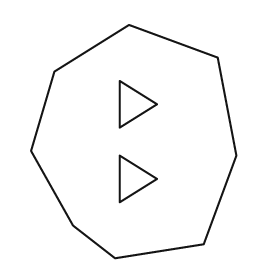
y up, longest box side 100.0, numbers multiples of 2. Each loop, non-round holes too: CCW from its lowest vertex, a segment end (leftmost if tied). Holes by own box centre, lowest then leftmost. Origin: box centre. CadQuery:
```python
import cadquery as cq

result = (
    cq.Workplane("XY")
    .moveTo(-8.0, -50.0)
    .lineTo(30.0, -44.0)
    .lineTo(44.0, -6.0)
    .lineTo(36.0, 36.0)
    .lineTo(-2.0, 50.0)
    .lineTo(-34.0, 30.0)
    .lineTo(-44.0, -4.0)
    .lineTo(-26.0, -36.0)
    .close()
    .moveTo(-6.0, -26.0)
    .lineTo(10.0, -16.0)
    .lineTo(-6.0, -6.0)
    .close()
    .moveTo(-6.0, 6.0)
    .lineTo(10.0, 16.0)
    .lineTo(-6.0, 26.0)
    .close()
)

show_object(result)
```